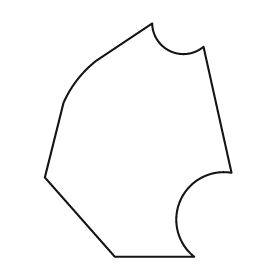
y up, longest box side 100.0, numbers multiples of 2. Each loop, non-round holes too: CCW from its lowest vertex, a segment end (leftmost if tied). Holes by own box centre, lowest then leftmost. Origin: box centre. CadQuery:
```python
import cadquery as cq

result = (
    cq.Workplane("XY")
    .moveTo(-10.0, -50.0)
    .lineTo(24.0, -50.0)
    .threePointArc((18.0, -26.0), (40.0, -14.0))
    .lineTo(28.0, 40.0)
    .threePointArc((14.0, 38.0), (6.0, 50.0))
    .lineTo(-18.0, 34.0)
    .threePointArc((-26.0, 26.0), (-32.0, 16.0))
    .lineTo(-40.0, -16.0)
    .close()
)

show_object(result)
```